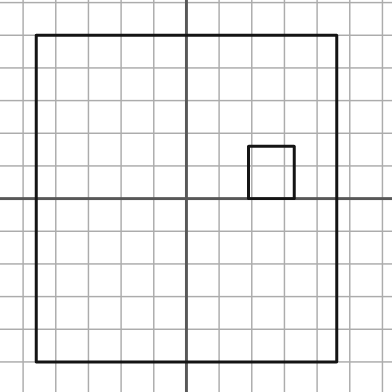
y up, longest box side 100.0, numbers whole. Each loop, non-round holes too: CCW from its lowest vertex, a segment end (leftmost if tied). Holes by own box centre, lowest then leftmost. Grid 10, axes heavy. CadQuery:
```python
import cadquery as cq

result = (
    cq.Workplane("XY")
    .moveTo(-46.0, -50.0)
    .lineTo(46.0, -50.0)
    .lineTo(46.0, 50.0)
    .lineTo(-46.0, 50.0)
    .close()
    .moveTo(19.0, 0.0)
    .lineTo(33.0, 0.0)
    .lineTo(33.0, 16.0)
    .lineTo(19.0, 16.0)
    .close()
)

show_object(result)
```